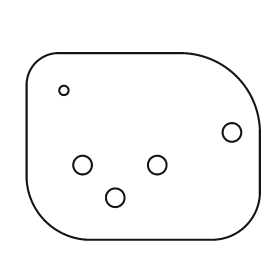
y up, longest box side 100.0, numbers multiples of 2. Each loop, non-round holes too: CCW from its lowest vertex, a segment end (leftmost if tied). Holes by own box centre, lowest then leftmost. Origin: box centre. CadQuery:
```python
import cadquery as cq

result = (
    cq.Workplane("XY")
    .moveTo(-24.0, -40.0)
    .lineTo(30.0, -40.0)
    .threePointArc((44.0, -34.0), (50.0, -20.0))
    .lineTo(50.0, 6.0)
    .threePointArc((40.0, 30.0), (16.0, 40.0))
    .lineTo(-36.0, 40.0)
    .threePointArc((-46.0, 36.0), (-50.0, 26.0))
    .lineTo(-50.0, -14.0)
    .threePointArc((-42.0, -32.0), (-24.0, -40.0))
    .close()
    .moveTo(-12.0, -22.0)
    .circle(4.0)
    .moveTo(-26.0, -8.0)
    .circle(4.0)
    .moveTo(6.0, -8.0)
    .circle(4.0)
    .moveTo(38.0, 6.0)
    .circle(4.0)
    .moveTo(-34.0, 24.0)
    .circle(2.0)
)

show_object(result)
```